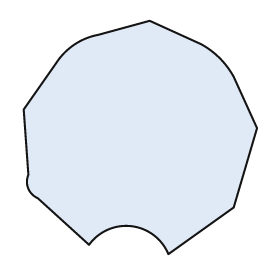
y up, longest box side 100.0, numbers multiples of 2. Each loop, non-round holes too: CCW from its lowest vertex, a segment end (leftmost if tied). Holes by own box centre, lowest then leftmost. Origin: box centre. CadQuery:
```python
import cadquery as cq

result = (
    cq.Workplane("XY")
    .moveTo(12.0, -50.0)
    .lineTo(40.0, -30.0)
    .lineTo(50.0, 4.0)
    .lineTo(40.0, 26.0)
    .threePointArc((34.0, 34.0), (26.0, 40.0))
    .lineTo(4.0, 50.0)
    .lineTo(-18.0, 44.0)
    .threePointArc((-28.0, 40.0), (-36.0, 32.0))
    .lineTo(-50.0, 12.0)
    .lineTo(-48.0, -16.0)
    .threePointArc((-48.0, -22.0), (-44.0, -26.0))
    .lineTo(-22.0, -46.0)
    .threePointArc((-4.0, -38.0), (12.0, -50.0))
    .close()
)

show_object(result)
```